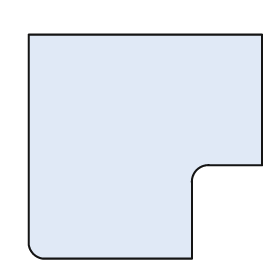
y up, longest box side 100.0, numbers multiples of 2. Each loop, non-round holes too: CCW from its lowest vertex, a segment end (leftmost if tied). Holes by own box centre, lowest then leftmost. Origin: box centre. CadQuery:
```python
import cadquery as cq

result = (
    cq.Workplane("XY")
    .moveTo(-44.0, -48.0)
    .lineTo(20.0, -48.0)
    .lineTo(20.0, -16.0)
    .threePointArc((22.0, -10.0), (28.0, -8.0))
    .lineTo(50.0, -8.0)
    .lineTo(50.0, 48.0)
    .lineTo(-50.0, 48.0)
    .lineTo(-50.0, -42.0)
    .threePointArc((-48.0, -46.0), (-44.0, -48.0))
    .close()
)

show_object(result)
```